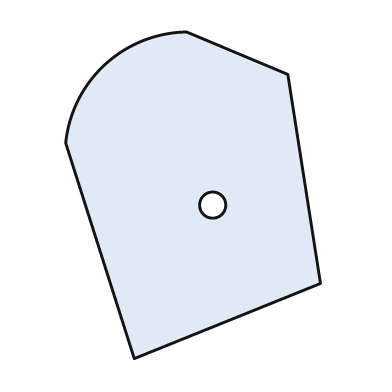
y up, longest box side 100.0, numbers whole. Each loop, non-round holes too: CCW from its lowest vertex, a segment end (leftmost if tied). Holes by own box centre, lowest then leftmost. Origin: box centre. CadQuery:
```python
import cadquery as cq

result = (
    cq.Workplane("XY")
    .moveTo(-18.0, -50.0)
    .lineTo(39.0, -27.0)
    .lineTo(29.0, 37.0)
    .lineTo(-2.0, 50.0)
    .threePointArc((-27.0, 40.0), (-39.0, 16.0))
    .close()
    .moveTo(6.0, -3.0)
    .circle(4.0)
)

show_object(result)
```